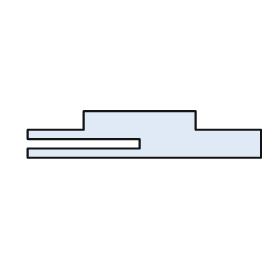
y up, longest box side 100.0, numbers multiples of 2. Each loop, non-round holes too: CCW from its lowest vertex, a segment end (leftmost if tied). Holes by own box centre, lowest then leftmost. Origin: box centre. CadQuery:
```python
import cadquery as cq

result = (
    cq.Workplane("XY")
    .moveTo(-50.0, -10.0)
    .lineTo(50.0, -10.0)
    .lineTo(50.0, 2.0)
    .lineTo(22.0, 2.0)
    .lineTo(22.0, 10.0)
    .lineTo(-26.0, 10.0)
    .lineTo(-26.0, 2.0)
    .lineTo(-50.0, 2.0)
    .lineTo(-50.0, -2.0)
    .lineTo(-2.0, -2.0)
    .lineTo(-2.0, -6.0)
    .lineTo(-50.0, -6.0)
    .close()
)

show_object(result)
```